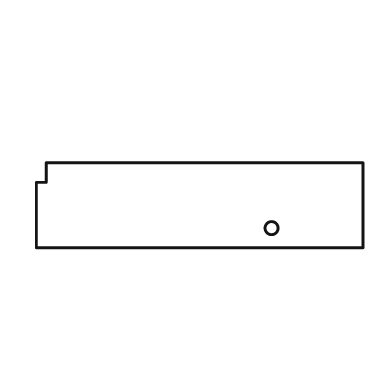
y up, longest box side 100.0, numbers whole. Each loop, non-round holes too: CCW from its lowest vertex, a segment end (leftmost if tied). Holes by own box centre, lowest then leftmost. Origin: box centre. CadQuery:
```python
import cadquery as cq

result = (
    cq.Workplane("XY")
    .moveTo(-50.0, -13.0)
    .lineTo(50.0, -13.0)
    .lineTo(50.0, 13.0)
    .lineTo(-47.0, 13.0)
    .lineTo(-47.0, 7.0)
    .lineTo(-50.0, 7.0)
    .close()
    .moveTo(22.0, -7.0)
    .circle(2.0)
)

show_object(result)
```